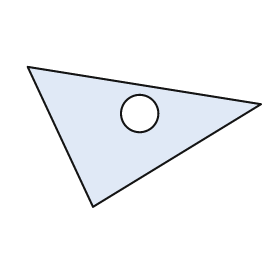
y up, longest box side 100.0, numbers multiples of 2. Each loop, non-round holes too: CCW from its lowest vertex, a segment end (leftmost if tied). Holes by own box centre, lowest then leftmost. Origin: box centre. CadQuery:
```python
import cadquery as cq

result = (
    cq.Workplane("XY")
    .moveTo(-22.0, -30.0)
    .lineTo(50.0, 14.0)
    .lineTo(-50.0, 30.0)
    .close()
    .moveTo(-2.0, 10.0)
    .circle(8.0)
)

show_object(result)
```